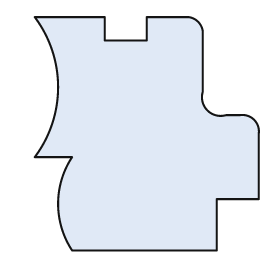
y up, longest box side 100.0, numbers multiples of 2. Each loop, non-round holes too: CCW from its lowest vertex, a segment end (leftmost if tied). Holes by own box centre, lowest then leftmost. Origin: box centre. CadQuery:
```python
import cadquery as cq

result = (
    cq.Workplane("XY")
    .moveTo(-32.0, -50.0)
    .lineTo(30.0, -50.0)
    .lineTo(30.0, -28.0)
    .lineTo(48.0, -28.0)
    .lineTo(48.0, 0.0)
    .threePointArc((46.0, 6.0), (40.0, 8.0))
    .lineTo(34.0, 8.0)
    .threePointArc((26.0, 10.0), (24.0, 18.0))
    .lineTo(24.0, 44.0)
    .threePointArc((22.0, 48.0), (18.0, 50.0))
    .lineTo(0.0, 50.0)
    .lineTo(0.0, 40.0)
    .lineTo(-18.0, 40.0)
    .lineTo(-18.0, 50.0)
    .lineTo(-48.0, 50.0)
    .threePointArc((-38.0, 20.0), (-48.0, -10.0))
    .lineTo(-32.0, -10.0)
    .threePointArc((-38.0, -30.0), (-32.0, -50.0))
    .close()
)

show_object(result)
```